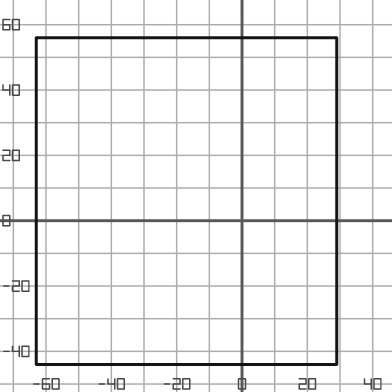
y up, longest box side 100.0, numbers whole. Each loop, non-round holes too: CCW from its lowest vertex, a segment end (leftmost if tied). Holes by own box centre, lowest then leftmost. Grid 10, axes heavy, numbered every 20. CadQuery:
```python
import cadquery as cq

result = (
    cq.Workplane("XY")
    .moveTo(-63.0, -44.0)
    .lineTo(29.0, -44.0)
    .lineTo(29.0, 56.0)
    .lineTo(-63.0, 56.0)
    .close()
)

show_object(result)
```